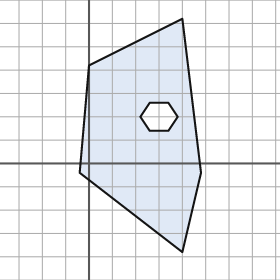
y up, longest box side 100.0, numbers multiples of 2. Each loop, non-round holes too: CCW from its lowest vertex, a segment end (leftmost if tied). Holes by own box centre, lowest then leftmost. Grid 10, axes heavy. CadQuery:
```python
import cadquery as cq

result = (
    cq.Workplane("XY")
    .moveTo(40.0, -38.0)
    .lineTo(48.0, -4.0)
    .lineTo(40.0, 62.0)
    .lineTo(0.0, 42.0)
    .lineTo(-4.0, -4.0)
    .close()
    .moveTo(26.0, 14.0)
    .lineTo(34.0, 14.0)
    .lineTo(38.0, 20.0)
    .lineTo(34.0, 26.0)
    .lineTo(26.0, 26.0)
    .lineTo(22.0, 20.0)
    .close()
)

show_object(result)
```